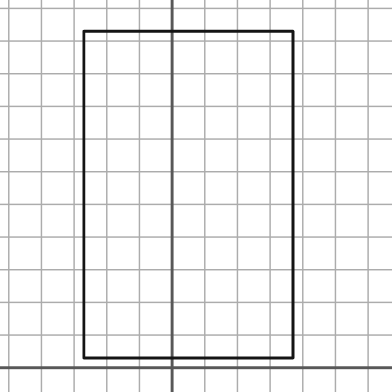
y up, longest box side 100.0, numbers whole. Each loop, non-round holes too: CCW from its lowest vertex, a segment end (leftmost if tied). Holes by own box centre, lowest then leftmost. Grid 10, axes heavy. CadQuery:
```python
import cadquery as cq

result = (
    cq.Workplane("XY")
    .moveTo(-27.0, 3.0)
    .lineTo(37.0, 3.0)
    .lineTo(37.0, 103.0)
    .lineTo(-27.0, 103.0)
    .close()
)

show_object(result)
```